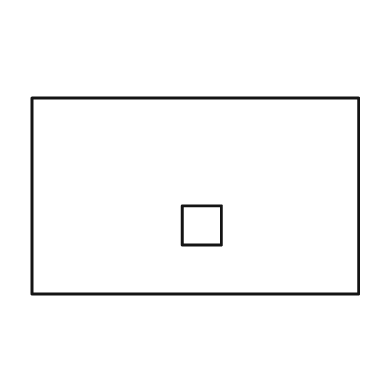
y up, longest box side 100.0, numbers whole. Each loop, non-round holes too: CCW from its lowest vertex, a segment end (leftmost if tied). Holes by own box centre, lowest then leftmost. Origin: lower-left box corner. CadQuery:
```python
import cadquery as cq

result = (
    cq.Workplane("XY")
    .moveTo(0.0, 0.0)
    .lineTo(100.0, 0.0)
    .lineTo(100.0, 60.0)
    .lineTo(0.0, 60.0)
    .close()
    .moveTo(46.0, 15.0)
    .lineTo(58.0, 15.0)
    .lineTo(58.0, 27.0)
    .lineTo(46.0, 27.0)
    .close()
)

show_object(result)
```